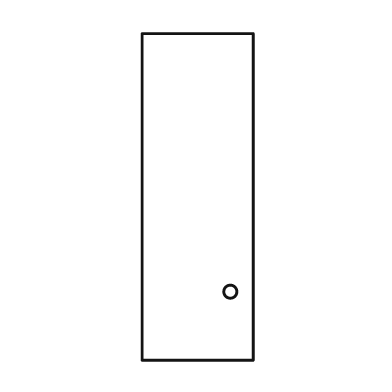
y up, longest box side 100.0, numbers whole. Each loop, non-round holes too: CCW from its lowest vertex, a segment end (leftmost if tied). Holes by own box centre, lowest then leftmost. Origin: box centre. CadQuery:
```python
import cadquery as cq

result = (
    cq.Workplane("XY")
    .moveTo(-17.0, -50.0)
    .lineTo(17.0, -50.0)
    .lineTo(17.0, 50.0)
    .lineTo(-17.0, 50.0)
    .close()
    .moveTo(10.0, -29.0)
    .circle(2.0)
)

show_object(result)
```